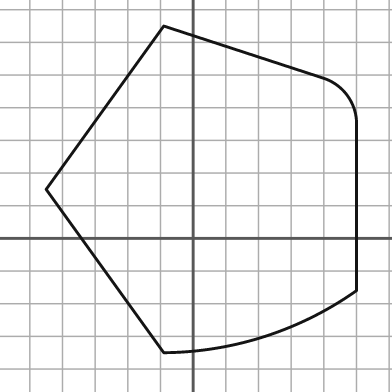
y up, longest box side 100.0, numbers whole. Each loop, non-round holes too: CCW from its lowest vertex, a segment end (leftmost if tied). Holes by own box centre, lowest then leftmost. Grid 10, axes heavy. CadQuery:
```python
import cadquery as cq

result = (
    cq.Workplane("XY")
    .moveTo(-9.0, -35.0)
    .threePointArc((22.0, -30.0), (50.0, -16.0))
    .lineTo(50.0, 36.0)
    .threePointArc((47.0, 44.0), (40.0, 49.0))
    .lineTo(-9.0, 65.0)
    .lineTo(-45.0, 15.0)
    .close()
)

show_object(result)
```